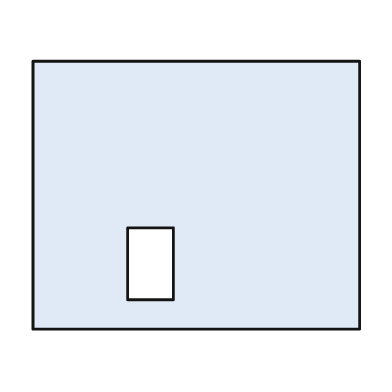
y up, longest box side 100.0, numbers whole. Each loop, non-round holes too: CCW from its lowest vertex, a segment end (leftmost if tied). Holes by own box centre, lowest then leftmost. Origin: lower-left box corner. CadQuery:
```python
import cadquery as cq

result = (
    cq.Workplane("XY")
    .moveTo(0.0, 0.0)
    .lineTo(100.0, 0.0)
    .lineTo(100.0, 82.0)
    .lineTo(0.0, 82.0)
    .close()
    .moveTo(29.0, 9.0)
    .lineTo(43.0, 9.0)
    .lineTo(43.0, 31.0)
    .lineTo(29.0, 31.0)
    .close()
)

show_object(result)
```